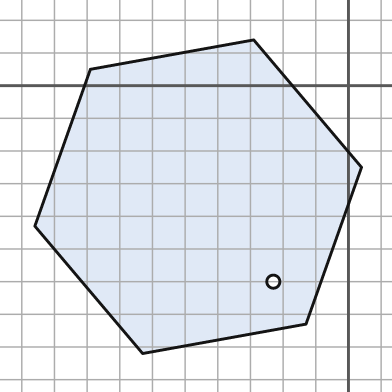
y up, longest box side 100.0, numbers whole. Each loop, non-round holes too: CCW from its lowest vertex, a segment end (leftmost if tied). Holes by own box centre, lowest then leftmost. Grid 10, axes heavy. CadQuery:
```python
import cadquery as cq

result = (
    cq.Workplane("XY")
    .moveTo(-63.0, -82.0)
    .lineTo(-13.0, -73.0)
    .lineTo(4.0, -25.0)
    .lineTo(-29.0, 14.0)
    .lineTo(-79.0, 5.0)
    .lineTo(-96.0, -43.0)
    .close()
    .moveTo(-23.0, -60.0)
    .circle(2.0)
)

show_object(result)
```